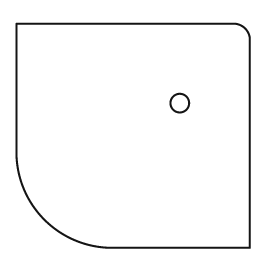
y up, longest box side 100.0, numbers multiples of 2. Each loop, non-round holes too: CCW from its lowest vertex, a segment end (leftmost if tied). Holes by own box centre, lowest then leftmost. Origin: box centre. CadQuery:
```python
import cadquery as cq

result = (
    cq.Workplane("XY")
    .moveTo(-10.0, -48.0)
    .lineTo(50.0, -48.0)
    .lineTo(50.0, 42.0)
    .threePointArc((48.0, 46.0), (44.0, 48.0))
    .lineTo(-50.0, 48.0)
    .lineTo(-50.0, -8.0)
    .threePointArc((-38.0, -36.0), (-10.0, -48.0))
    .close()
    .moveTo(20.0, 14.0)
    .circle(4.0)
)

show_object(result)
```